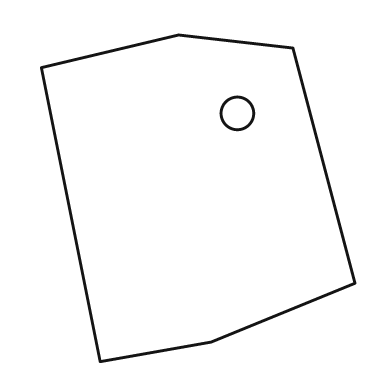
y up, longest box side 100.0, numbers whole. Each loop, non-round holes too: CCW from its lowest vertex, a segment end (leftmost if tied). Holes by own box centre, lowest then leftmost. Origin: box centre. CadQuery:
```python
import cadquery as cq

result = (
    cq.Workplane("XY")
    .moveTo(-30.0, -50.0)
    .lineTo(4.0, -44.0)
    .lineTo(48.0, -26.0)
    .lineTo(29.0, 46.0)
    .lineTo(-6.0, 50.0)
    .lineTo(-48.0, 40.0)
    .close()
    .moveTo(12.0, 26.0)
    .circle(5.0)
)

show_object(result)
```